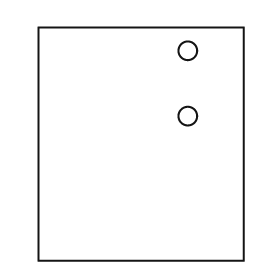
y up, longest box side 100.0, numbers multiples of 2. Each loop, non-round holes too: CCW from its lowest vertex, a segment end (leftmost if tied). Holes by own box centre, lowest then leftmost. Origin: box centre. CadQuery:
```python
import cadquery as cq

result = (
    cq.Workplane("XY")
    .moveTo(-44.0, -50.0)
    .lineTo(44.0, -50.0)
    .lineTo(44.0, 50.0)
    .lineTo(-44.0, 50.0)
    .close()
    .moveTo(20.0, 12.0)
    .circle(4.0)
    .moveTo(20.0, 40.0)
    .circle(4.0)
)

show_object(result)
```